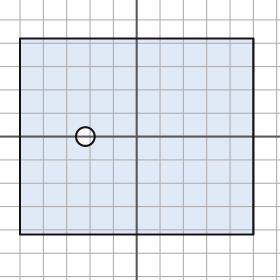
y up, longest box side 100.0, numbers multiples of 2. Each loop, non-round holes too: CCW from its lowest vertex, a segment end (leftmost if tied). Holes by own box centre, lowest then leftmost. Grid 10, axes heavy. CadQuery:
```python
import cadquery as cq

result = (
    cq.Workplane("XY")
    .moveTo(-50.0, -42.0)
    .lineTo(50.0, -42.0)
    .lineTo(50.0, 42.0)
    .lineTo(-50.0, 42.0)
    .close()
    .moveTo(-22.0, 0.0)
    .circle(4.0)
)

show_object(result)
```